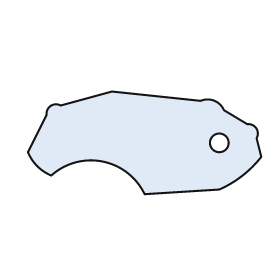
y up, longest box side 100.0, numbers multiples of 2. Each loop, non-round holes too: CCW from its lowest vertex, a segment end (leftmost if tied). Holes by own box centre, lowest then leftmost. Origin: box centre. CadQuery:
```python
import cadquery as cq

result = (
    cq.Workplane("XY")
    .moveTo(0.0, -22.0)
    .lineTo(32.0, -20.0)
    .threePointArc((42.0, -14.0), (50.0, -6.0))
    .lineTo(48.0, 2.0)
    .threePointArc((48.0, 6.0), (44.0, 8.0))
    .lineTo(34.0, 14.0)
    .threePointArc((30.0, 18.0), (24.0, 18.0))
    .lineTo(-14.0, 22.0)
    .lineTo(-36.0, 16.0)
    .threePointArc((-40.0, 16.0), (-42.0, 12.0))
    .lineTo(-50.0, -4.0)
    .threePointArc((-46.0, -10.0), (-40.0, -14.0))
    .threePointArc((-18.0, -8.0), (0.0, -22.0))
    .close()
    .moveTo(32.0, 0.0)
    .circle(4.0)
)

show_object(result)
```